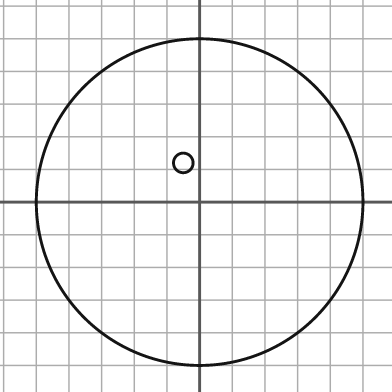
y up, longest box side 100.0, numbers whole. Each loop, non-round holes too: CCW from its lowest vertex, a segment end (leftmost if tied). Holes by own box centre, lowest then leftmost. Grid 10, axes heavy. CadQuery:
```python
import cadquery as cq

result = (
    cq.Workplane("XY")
    .moveTo(0.0, 0.0)
    .circle(50.0)
    .moveTo(-5.0, 12.0)
    .circle(3.0)
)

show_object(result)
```